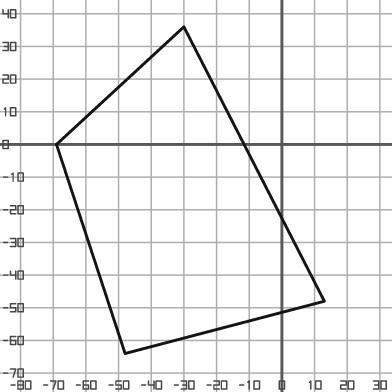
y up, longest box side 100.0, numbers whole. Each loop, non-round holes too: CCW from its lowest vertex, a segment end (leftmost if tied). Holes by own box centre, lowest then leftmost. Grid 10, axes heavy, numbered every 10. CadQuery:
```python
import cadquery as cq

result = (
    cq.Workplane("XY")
    .moveTo(-48.0, -64.0)
    .lineTo(13.0, -48.0)
    .lineTo(-30.0, 36.0)
    .lineTo(-69.0, 0.0)
    .close()
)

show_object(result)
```